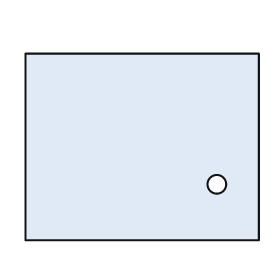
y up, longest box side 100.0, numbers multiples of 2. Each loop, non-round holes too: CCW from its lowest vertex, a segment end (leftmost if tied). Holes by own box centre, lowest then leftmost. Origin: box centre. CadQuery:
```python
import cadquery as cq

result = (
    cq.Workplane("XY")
    .moveTo(-50.0, -40.0)
    .lineTo(50.0, -40.0)
    .lineTo(50.0, 40.0)
    .lineTo(-50.0, 40.0)
    .close()
    .moveTo(32.0, -16.0)
    .circle(4.0)
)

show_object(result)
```